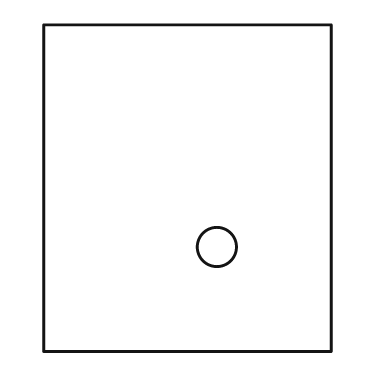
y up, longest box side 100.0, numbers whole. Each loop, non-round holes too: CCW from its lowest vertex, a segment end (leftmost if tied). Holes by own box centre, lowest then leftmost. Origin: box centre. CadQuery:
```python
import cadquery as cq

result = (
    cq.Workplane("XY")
    .moveTo(-44.0, -50.0)
    .lineTo(44.0, -50.0)
    .lineTo(44.0, 50.0)
    .lineTo(-44.0, 50.0)
    .close()
    .moveTo(9.0, -18.0)
    .circle(6.0)
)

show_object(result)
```